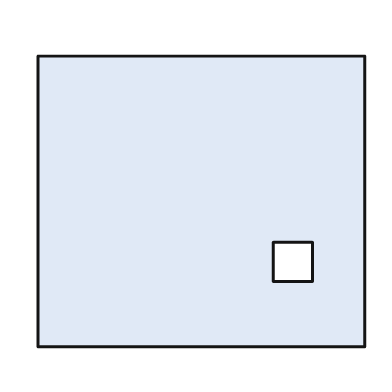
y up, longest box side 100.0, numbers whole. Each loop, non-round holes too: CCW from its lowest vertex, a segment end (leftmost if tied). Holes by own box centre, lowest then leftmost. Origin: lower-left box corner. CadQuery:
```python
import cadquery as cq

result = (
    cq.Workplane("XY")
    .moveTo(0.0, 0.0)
    .lineTo(100.0, 0.0)
    .lineTo(100.0, 89.0)
    .lineTo(0.0, 89.0)
    .close()
    .moveTo(72.0, 20.0)
    .lineTo(84.0, 20.0)
    .lineTo(84.0, 32.0)
    .lineTo(72.0, 32.0)
    .close()
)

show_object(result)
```